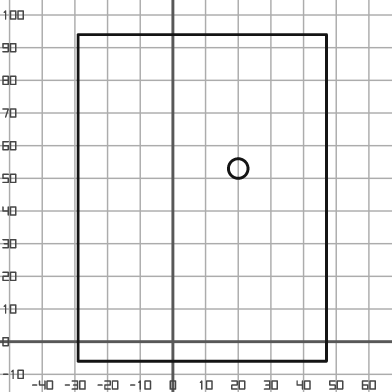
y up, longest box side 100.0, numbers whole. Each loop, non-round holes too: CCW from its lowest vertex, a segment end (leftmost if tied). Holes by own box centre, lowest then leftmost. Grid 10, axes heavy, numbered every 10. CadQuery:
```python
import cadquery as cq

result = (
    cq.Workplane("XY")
    .moveTo(-29.0, -6.0)
    .lineTo(47.0, -6.0)
    .lineTo(47.0, 94.0)
    .lineTo(-29.0, 94.0)
    .close()
    .moveTo(20.0, 53.0)
    .circle(3.0)
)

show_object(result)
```